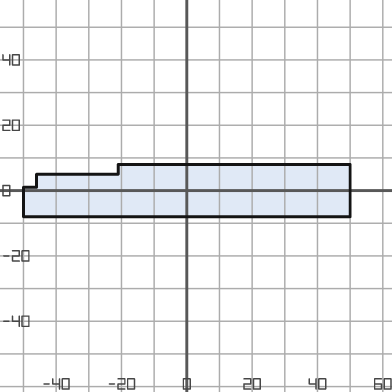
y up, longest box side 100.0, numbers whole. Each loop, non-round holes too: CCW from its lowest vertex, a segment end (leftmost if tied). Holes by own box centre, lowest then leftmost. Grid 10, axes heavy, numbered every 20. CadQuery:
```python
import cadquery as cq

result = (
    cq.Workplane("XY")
    .moveTo(-50.0, -8.0)
    .lineTo(50.0, -8.0)
    .lineTo(50.0, 8.0)
    .lineTo(-21.0, 8.0)
    .lineTo(-21.0, 5.0)
    .lineTo(-46.0, 5.0)
    .lineTo(-46.0, 1.0)
    .lineTo(-50.0, 1.0)
    .close()
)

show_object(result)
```